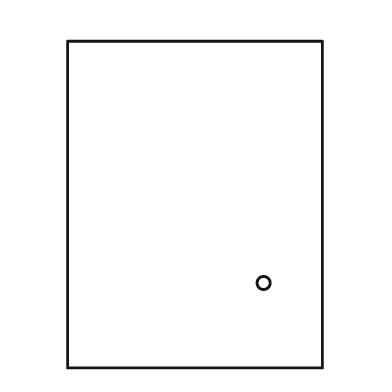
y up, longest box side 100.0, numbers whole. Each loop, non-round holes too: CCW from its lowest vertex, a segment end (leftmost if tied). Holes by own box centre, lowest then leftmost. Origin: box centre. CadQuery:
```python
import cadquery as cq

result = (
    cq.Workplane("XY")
    .moveTo(-39.0, -50.0)
    .lineTo(39.0, -50.0)
    .lineTo(39.0, 50.0)
    .lineTo(-39.0, 50.0)
    .close()
    .moveTo(21.0, -24.0)
    .circle(2.0)
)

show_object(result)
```